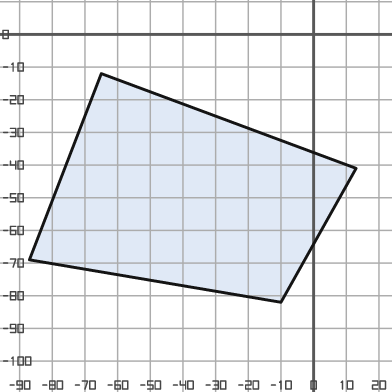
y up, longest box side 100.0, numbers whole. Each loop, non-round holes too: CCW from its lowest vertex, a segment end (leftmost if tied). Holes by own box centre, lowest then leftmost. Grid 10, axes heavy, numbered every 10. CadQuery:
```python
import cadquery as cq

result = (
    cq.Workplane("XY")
    .moveTo(-10.0, -82.0)
    .lineTo(13.0, -41.0)
    .lineTo(-65.0, -12.0)
    .lineTo(-87.0, -69.0)
    .close()
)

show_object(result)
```